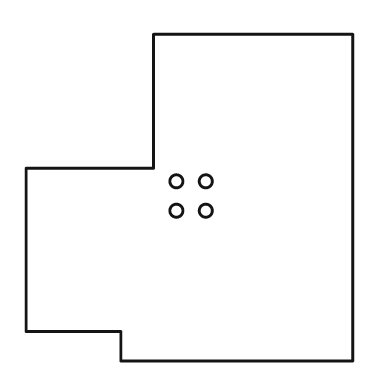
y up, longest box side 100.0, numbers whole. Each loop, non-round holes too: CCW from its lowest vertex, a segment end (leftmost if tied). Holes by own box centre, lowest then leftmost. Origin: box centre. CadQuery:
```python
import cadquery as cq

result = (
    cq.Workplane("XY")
    .moveTo(-21.0, -50.0)
    .lineTo(50.0, -50.0)
    .lineTo(50.0, 50.0)
    .lineTo(-11.0, 50.0)
    .lineTo(-11.0, 9.0)
    .lineTo(-50.0, 9.0)
    .lineTo(-50.0, -41.0)
    .lineTo(-21.0, -41.0)
    .close()
    .moveTo(-4.0, -4.0)
    .circle(2.0)
    .moveTo(5.0, -4.0)
    .circle(2.0)
    .moveTo(-4.0, 5.0)
    .circle(2.0)
    .moveTo(5.0, 5.0)
    .circle(2.0)
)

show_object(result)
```